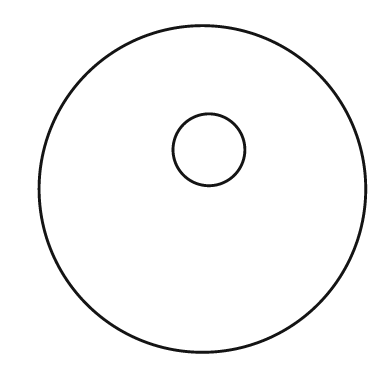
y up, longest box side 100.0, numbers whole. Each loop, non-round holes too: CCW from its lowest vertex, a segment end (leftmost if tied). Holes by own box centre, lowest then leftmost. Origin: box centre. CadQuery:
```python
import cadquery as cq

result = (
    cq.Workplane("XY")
    .moveTo(0.0, 0.0)
    .circle(50.0)
    .moveTo(2.0, 12.0)
    .circle(11.0)
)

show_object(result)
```